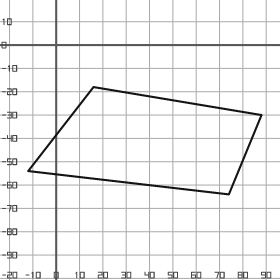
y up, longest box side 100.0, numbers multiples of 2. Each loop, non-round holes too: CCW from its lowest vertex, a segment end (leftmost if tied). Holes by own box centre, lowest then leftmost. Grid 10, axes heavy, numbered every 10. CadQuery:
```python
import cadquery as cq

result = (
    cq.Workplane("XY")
    .moveTo(74.0, -64.0)
    .lineTo(88.0, -30.0)
    .lineTo(16.0, -18.0)
    .lineTo(-12.0, -54.0)
    .close()
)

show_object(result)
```